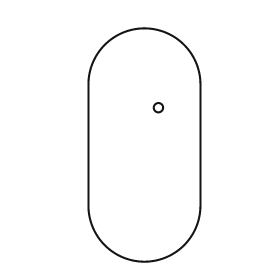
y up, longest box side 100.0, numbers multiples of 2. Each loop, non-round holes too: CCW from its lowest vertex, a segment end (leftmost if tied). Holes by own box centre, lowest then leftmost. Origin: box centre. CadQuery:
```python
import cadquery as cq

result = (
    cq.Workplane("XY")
    .moveTo(-24.0, -26.0)
    .threePointArc((0.0, -50.0), (24.0, -26.0))
    .lineTo(24.0, 26.0)
    .threePointArc((0.0, 50.0), (-24.0, 26.0))
    .close()
    .moveTo(6.0, 16.0)
    .circle(2.0)
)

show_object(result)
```